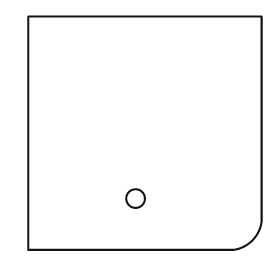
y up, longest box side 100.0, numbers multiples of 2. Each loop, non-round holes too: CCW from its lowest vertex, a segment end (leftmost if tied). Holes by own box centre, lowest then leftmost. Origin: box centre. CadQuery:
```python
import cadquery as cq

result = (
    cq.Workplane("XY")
    .moveTo(-50.0, -50.0)
    .lineTo(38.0, -50.0)
    .threePointArc((46.0, -46.0), (50.0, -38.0))
    .lineTo(50.0, 50.0)
    .lineTo(-50.0, 50.0)
    .close()
    .moveTo(-4.0, -28.0)
    .circle(4.0)
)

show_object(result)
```